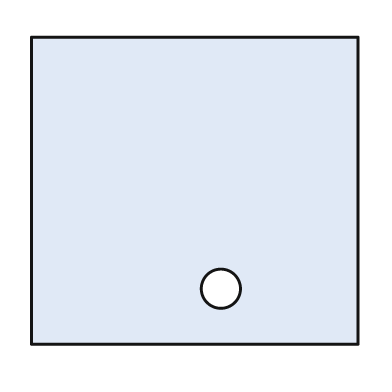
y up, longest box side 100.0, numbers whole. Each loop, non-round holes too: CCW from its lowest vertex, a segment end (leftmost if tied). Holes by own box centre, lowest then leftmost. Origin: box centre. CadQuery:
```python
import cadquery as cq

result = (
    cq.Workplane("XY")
    .moveTo(-50.0, -47.0)
    .lineTo(50.0, -47.0)
    .lineTo(50.0, 47.0)
    .lineTo(-50.0, 47.0)
    .close()
    .moveTo(8.0, -30.0)
    .circle(6.0)
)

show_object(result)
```